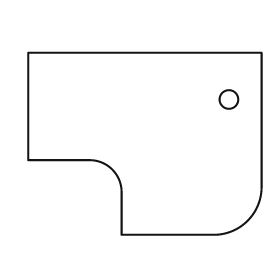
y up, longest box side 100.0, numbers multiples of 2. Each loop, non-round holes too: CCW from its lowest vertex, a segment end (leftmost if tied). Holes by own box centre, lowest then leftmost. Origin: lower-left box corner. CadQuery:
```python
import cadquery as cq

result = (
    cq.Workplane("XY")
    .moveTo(40.0, 0.0)
    .lineTo(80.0, 0.0)
    .threePointArc((94.0, 6.0), (100.0, 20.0))
    .lineTo(100.0, 78.0)
    .lineTo(0.0, 78.0)
    .lineTo(0.0, 32.0)
    .lineTo(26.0, 32.0)
    .threePointArc((36.0, 28.0), (40.0, 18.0))
    .close()
    .moveTo(86.0, 58.0)
    .circle(4.0)
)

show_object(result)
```